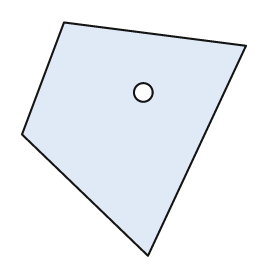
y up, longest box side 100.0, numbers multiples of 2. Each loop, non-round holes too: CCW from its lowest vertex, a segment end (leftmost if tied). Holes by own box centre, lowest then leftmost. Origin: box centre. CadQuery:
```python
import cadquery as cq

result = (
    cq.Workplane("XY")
    .moveTo(6.0, -50.0)
    .lineTo(48.0, 40.0)
    .lineTo(-30.0, 50.0)
    .lineTo(-48.0, 2.0)
    .close()
    .moveTo(4.0, 20.0)
    .circle(4.0)
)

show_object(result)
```